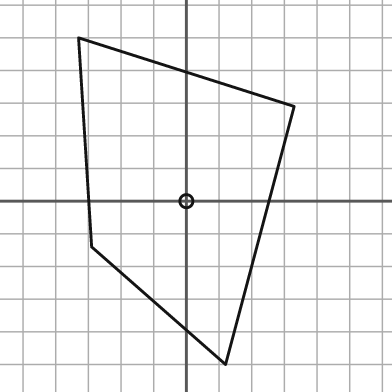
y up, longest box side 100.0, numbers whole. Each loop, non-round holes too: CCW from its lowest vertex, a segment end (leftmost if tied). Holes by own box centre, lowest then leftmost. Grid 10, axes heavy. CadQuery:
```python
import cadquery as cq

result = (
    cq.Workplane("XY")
    .moveTo(12.0, -50.0)
    .lineTo(33.0, 29.0)
    .lineTo(-33.0, 50.0)
    .lineTo(-29.0, -14.0)
    .close()
    .moveTo(0.0, 0.0)
    .circle(2.0)
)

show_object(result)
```